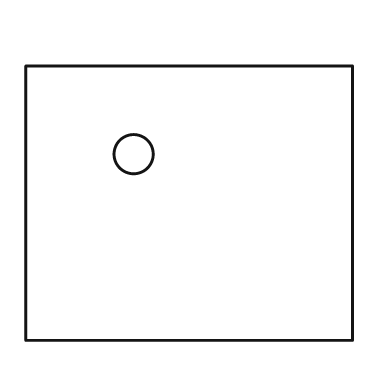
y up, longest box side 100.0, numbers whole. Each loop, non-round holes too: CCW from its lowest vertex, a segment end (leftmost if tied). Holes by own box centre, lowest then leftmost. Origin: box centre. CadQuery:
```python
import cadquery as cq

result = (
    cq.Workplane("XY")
    .moveTo(-50.0, -42.0)
    .lineTo(50.0, -42.0)
    .lineTo(50.0, 42.0)
    .lineTo(-50.0, 42.0)
    .close()
    .moveTo(-17.0, 15.0)
    .circle(6.0)
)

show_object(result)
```